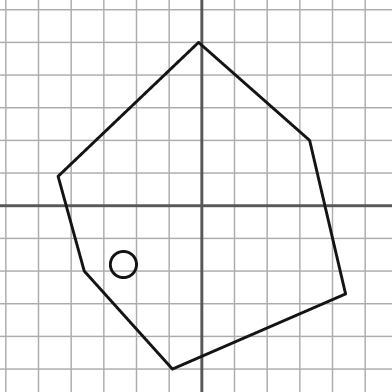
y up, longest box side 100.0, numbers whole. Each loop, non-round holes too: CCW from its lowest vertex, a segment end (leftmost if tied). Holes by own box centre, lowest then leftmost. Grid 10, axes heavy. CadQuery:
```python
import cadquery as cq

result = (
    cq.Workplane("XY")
    .moveTo(-9.0, -50.0)
    .lineTo(44.0, -27.0)
    .lineTo(33.0, 20.0)
    .lineTo(-1.0, 50.0)
    .lineTo(-44.0, 9.0)
    .lineTo(-36.0, -20.0)
    .close()
    .moveTo(-24.0, -18.0)
    .circle(4.0)
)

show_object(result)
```